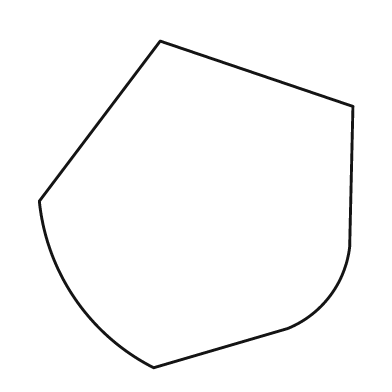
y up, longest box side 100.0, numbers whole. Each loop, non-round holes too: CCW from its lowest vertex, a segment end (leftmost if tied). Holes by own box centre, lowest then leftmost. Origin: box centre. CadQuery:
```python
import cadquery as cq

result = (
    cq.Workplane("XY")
    .moveTo(-13.0, -50.0)
    .lineTo(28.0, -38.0)
    .threePointArc((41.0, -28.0), (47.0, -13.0))
    .lineTo(48.0, 30.0)
    .lineTo(-11.0, 50.0)
    .lineTo(-48.0, 1.0)
    .threePointArc((-37.0, -29.0), (-13.0, -50.0))
    .close()
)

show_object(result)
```